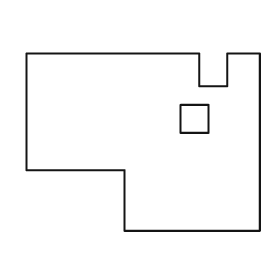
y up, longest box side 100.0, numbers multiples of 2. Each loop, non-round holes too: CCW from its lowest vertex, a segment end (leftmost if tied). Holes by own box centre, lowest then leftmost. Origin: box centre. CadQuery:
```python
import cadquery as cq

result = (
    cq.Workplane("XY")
    .moveTo(-8.0, -38.0)
    .lineTo(50.0, -38.0)
    .lineTo(50.0, 38.0)
    .lineTo(36.0, 38.0)
    .lineTo(36.0, 24.0)
    .lineTo(24.0, 24.0)
    .lineTo(24.0, 38.0)
    .lineTo(-50.0, 38.0)
    .lineTo(-50.0, -12.0)
    .lineTo(-8.0, -12.0)
    .close()
    .moveTo(16.0, 4.0)
    .lineTo(28.0, 4.0)
    .lineTo(28.0, 16.0)
    .lineTo(16.0, 16.0)
    .close()
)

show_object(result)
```